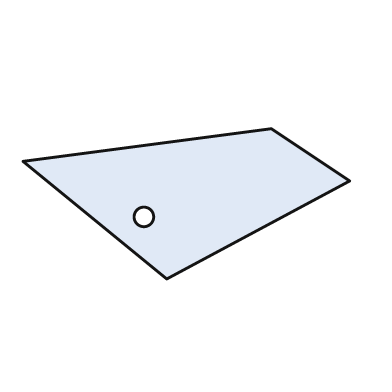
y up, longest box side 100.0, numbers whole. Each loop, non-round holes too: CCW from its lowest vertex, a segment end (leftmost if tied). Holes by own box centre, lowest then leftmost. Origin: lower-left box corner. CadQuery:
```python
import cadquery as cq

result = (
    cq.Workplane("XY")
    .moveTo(44.0, 0.0)
    .lineTo(100.0, 30.0)
    .lineTo(76.0, 46.0)
    .lineTo(0.0, 36.0)
    .close()
    .moveTo(37.0, 19.0)
    .circle(3.0)
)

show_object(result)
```